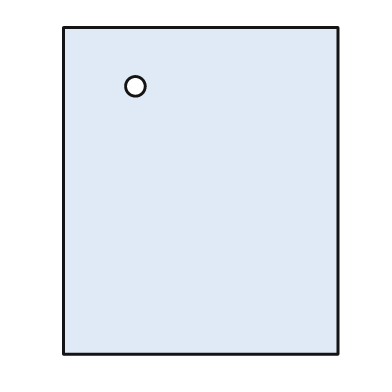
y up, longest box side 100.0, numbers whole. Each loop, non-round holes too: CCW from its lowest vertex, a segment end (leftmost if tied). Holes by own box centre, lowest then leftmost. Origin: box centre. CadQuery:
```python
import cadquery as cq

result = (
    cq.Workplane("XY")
    .moveTo(-42.0, -50.0)
    .lineTo(42.0, -50.0)
    .lineTo(42.0, 50.0)
    .lineTo(-42.0, 50.0)
    .close()
    .moveTo(-20.0, 32.0)
    .circle(3.0)
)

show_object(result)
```